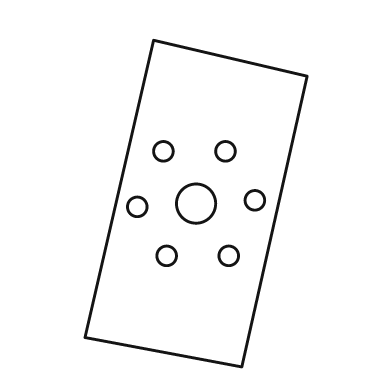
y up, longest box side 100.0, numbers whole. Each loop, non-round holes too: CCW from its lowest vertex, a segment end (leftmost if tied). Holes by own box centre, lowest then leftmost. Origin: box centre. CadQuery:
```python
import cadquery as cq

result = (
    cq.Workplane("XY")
    .moveTo(14.0, -50.0)
    .lineTo(34.0, 39.0)
    .lineTo(-13.0, 50.0)
    .lineTo(-34.0, -41.0)
    .close()
    .moveTo(-9.0, -16.0)
    .circle(3.0)
    .moveTo(10.0, -16.0)
    .circle(3.0)
    .moveTo(-18.0, -1.0)
    .circle(3.0)
    .moveTo(0.0, 0.0)
    .circle(6.0)
    .moveTo(18.0, 1.0)
    .circle(3.0)
    .moveTo(-10.0, 16.0)
    .circle(3.0)
    .moveTo(9.0, 16.0)
    .circle(3.0)
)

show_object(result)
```